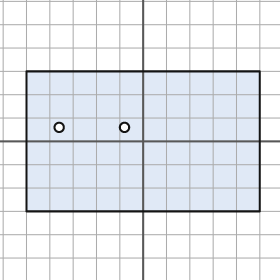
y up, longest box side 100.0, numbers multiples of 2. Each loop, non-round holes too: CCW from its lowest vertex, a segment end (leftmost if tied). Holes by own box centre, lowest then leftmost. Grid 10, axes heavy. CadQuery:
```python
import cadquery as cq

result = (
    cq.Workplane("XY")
    .moveTo(-50.0, -30.0)
    .lineTo(50.0, -30.0)
    .lineTo(50.0, 30.0)
    .lineTo(-50.0, 30.0)
    .close()
    .moveTo(-36.0, 6.0)
    .circle(2.0)
    .moveTo(-8.0, 6.0)
    .circle(2.0)
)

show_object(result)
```